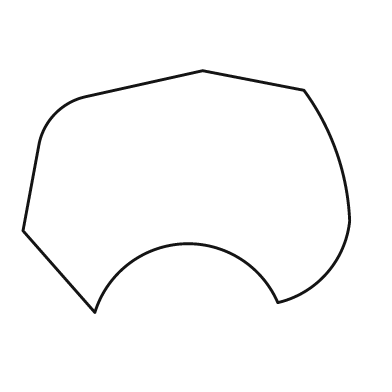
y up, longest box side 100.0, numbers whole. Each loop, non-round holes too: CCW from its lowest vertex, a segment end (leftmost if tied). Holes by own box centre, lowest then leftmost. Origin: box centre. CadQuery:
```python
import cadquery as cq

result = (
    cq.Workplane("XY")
    .moveTo(-28.0, -37.0)
    .threePointArc((-1.0, -16.0), (28.0, -34.0))
    .threePointArc((43.0, -25.0), (50.0, -9.0))
    .threePointArc((46.0, 12.0), (36.0, 31.0))
    .lineTo(5.0, 37.0)
    .lineTo(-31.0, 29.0)
    .threePointArc((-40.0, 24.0), (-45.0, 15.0))
    .lineTo(-50.0, -12.0)
    .close()
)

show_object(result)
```